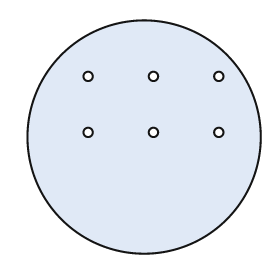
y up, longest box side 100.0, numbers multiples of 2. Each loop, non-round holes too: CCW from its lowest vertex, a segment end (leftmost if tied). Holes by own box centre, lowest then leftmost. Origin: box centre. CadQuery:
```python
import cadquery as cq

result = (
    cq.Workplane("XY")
    .moveTo(0.0, 0.0)
    .circle(50.0)
    .moveTo(-24.0, 2.0)
    .circle(2.0)
    .moveTo(4.0, 2.0)
    .circle(2.0)
    .moveTo(32.0, 2.0)
    .circle(2.0)
    .moveTo(-24.0, 26.0)
    .circle(2.0)
    .moveTo(4.0, 26.0)
    .circle(2.0)
    .moveTo(32.0, 26.0)
    .circle(2.0)
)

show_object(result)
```